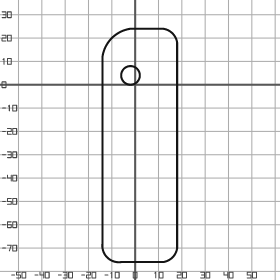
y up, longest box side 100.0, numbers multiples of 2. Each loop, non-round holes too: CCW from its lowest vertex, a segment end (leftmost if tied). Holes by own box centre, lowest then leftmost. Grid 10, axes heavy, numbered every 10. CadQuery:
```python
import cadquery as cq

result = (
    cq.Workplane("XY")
    .moveTo(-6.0, -76.0)
    .lineTo(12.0, -76.0)
    .threePointArc((16.0, -74.0), (18.0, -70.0))
    .lineTo(18.0, 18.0)
    .threePointArc((16.0, 22.0), (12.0, 24.0))
    .lineTo(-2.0, 24.0)
    .threePointArc((-10.0, 20.0), (-14.0, 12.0))
    .lineTo(-14.0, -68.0)
    .threePointArc((-12.0, -74.0), (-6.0, -76.0))
    .close()
    .moveTo(-2.0, 4.0)
    .circle(4.0)
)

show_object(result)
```